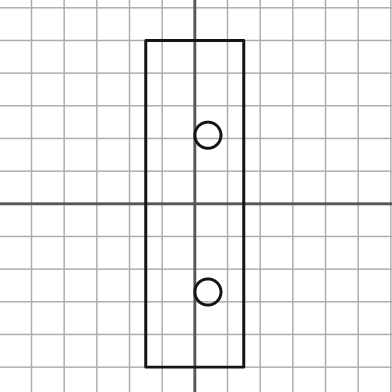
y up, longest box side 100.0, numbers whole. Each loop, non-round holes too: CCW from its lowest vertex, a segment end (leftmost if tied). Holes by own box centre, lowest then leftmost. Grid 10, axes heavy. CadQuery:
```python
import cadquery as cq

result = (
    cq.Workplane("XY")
    .moveTo(-15.0, -50.0)
    .lineTo(15.0, -50.0)
    .lineTo(15.0, 50.0)
    .lineTo(-15.0, 50.0)
    .close()
    .moveTo(4.0, -27.0)
    .circle(4.0)
    .moveTo(4.0, 21.0)
    .circle(4.0)
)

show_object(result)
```